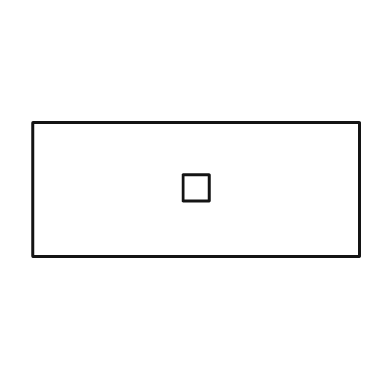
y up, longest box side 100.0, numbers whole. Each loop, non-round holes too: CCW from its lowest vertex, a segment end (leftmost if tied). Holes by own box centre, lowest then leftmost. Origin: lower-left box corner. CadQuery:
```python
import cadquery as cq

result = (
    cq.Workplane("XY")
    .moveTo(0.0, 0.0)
    .lineTo(100.0, 0.0)
    .lineTo(100.0, 41.0)
    .lineTo(0.0, 41.0)
    .close()
    .moveTo(46.0, 17.0)
    .lineTo(54.0, 17.0)
    .lineTo(54.0, 25.0)
    .lineTo(46.0, 25.0)
    .close()
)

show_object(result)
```